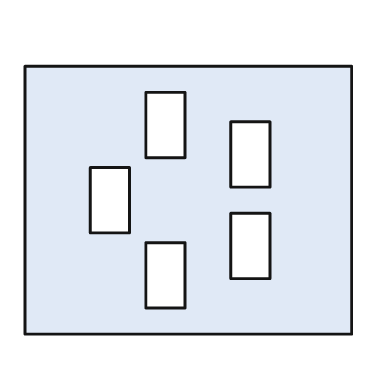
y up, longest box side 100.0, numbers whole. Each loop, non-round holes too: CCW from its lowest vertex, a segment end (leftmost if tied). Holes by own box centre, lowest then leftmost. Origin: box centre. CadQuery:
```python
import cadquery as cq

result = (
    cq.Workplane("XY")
    .moveTo(-50.0, -41.0)
    .lineTo(50.0, -41.0)
    .lineTo(50.0, 41.0)
    .lineTo(-50.0, 41.0)
    .close()
    .moveTo(-13.0, -33.0)
    .lineTo(-1.0, -33.0)
    .lineTo(-1.0, -13.0)
    .lineTo(-13.0, -13.0)
    .close()
    .moveTo(13.0, -24.0)
    .lineTo(25.0, -24.0)
    .lineTo(25.0, -4.0)
    .lineTo(13.0, -4.0)
    .close()
    .moveTo(-30.0, -10.0)
    .lineTo(-18.0, -10.0)
    .lineTo(-18.0, 10.0)
    .lineTo(-30.0, 10.0)
    .close()
    .moveTo(13.0, 4.0)
    .lineTo(25.0, 4.0)
    .lineTo(25.0, 24.0)
    .lineTo(13.0, 24.0)
    .close()
    .moveTo(-13.0, 13.0)
    .lineTo(-1.0, 13.0)
    .lineTo(-1.0, 33.0)
    .lineTo(-13.0, 33.0)
    .close()
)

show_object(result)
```